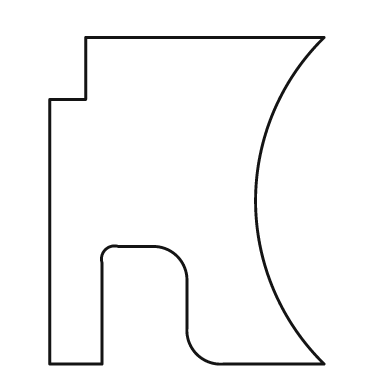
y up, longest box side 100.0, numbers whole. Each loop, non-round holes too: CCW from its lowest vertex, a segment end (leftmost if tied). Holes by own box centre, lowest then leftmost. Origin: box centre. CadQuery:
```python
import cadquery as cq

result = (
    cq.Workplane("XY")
    .moveTo(-42.0, -50.0)
    .lineTo(-26.0, -50.0)
    .lineTo(-26.0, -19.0)
    .threePointArc((-25.0, -15.0), (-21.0, -14.0))
    .lineTo(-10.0, -14.0)
    .threePointArc((-3.0, -17.0), (0.0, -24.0))
    .lineTo(0.0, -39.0)
    .threePointArc((3.0, -47.0), (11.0, -50.0))
    .lineTo(42.0, -50.0)
    .threePointArc((21.0, 0.0), (42.0, 50.0))
    .lineTo(-31.0, 50.0)
    .lineTo(-31.0, 31.0)
    .lineTo(-42.0, 31.0)
    .close()
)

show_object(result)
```